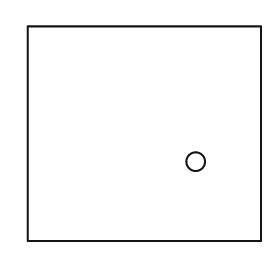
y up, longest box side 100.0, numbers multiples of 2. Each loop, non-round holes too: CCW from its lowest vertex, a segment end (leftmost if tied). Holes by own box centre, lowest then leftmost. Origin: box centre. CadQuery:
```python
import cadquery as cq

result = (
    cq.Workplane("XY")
    .moveTo(-50.0, -46.0)
    .lineTo(50.0, -46.0)
    .lineTo(50.0, 46.0)
    .lineTo(-50.0, 46.0)
    .close()
    .moveTo(22.0, -12.0)
    .circle(4.0)
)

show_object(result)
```